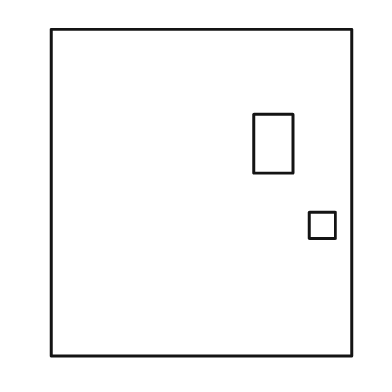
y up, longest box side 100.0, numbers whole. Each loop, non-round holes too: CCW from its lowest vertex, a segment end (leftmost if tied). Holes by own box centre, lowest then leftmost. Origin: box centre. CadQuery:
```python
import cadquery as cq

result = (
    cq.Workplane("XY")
    .moveTo(-46.0, -50.0)
    .lineTo(46.0, -50.0)
    .lineTo(46.0, 50.0)
    .lineTo(-46.0, 50.0)
    .close()
    .moveTo(33.0, -14.0)
    .lineTo(41.0, -14.0)
    .lineTo(41.0, -6.0)
    .lineTo(33.0, -6.0)
    .close()
    .moveTo(16.0, 6.0)
    .lineTo(28.0, 6.0)
    .lineTo(28.0, 24.0)
    .lineTo(16.0, 24.0)
    .close()
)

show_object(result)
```